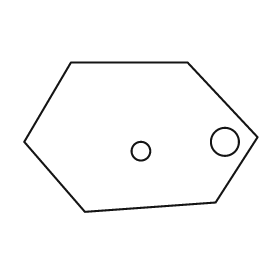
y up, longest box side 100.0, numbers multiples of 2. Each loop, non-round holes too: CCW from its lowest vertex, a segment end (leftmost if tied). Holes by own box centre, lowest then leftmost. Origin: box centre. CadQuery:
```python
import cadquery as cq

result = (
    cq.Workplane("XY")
    .moveTo(-24.0, -32.0)
    .lineTo(32.0, -28.0)
    .lineTo(50.0, 0.0)
    .lineTo(20.0, 32.0)
    .lineTo(-30.0, 32.0)
    .lineTo(-50.0, -2.0)
    .close()
    .moveTo(0.0, -6.0)
    .circle(4.0)
    .moveTo(36.0, -2.0)
    .circle(6.0)
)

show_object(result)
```